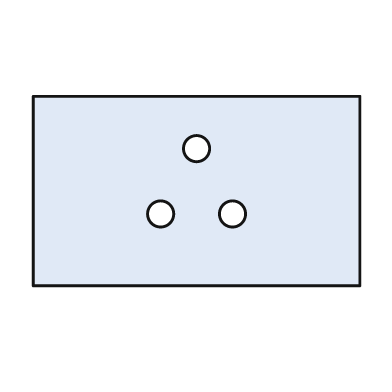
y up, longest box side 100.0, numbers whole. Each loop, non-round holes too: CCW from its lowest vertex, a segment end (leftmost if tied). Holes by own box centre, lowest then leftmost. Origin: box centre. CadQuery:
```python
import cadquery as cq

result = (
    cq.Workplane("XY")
    .moveTo(-50.0, -29.0)
    .lineTo(50.0, -29.0)
    .lineTo(50.0, 29.0)
    .lineTo(-50.0, 29.0)
    .close()
    .moveTo(-11.0, -7.0)
    .circle(4.0)
    .moveTo(11.0, -7.0)
    .circle(4.0)
    .moveTo(0.0, 13.0)
    .circle(4.0)
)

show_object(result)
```